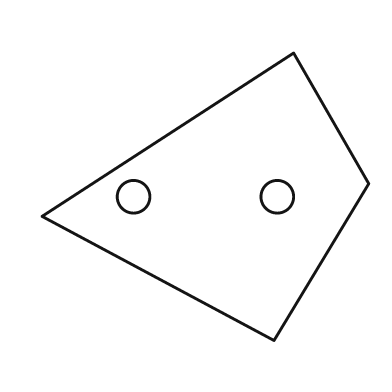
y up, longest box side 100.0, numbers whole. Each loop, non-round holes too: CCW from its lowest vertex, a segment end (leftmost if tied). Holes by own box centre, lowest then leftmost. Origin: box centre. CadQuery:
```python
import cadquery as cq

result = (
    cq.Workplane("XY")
    .moveTo(21.0, -44.0)
    .lineTo(50.0, 4.0)
    .lineTo(27.0, 44.0)
    .lineTo(-50.0, -6.0)
    .close()
    .moveTo(-22.0, 0.0)
    .circle(5.0)
    .moveTo(22.0, 0.0)
    .circle(5.0)
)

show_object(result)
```